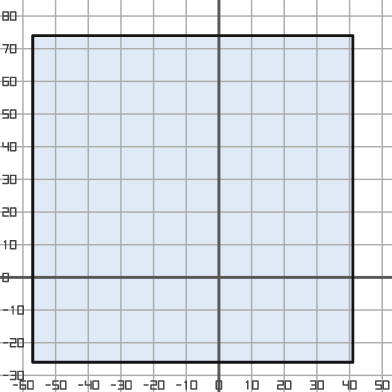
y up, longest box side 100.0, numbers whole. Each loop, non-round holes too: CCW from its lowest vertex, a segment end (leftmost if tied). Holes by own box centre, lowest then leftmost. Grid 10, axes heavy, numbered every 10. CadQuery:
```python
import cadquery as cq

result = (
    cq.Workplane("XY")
    .moveTo(-57.0, -26.0)
    .lineTo(41.0, -26.0)
    .lineTo(41.0, 74.0)
    .lineTo(-57.0, 74.0)
    .close()
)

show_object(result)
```